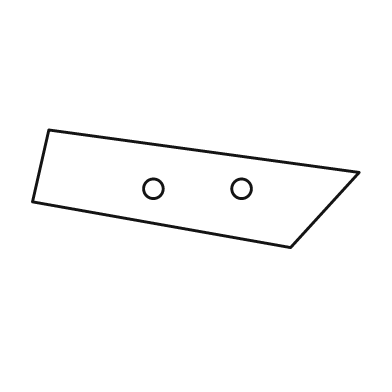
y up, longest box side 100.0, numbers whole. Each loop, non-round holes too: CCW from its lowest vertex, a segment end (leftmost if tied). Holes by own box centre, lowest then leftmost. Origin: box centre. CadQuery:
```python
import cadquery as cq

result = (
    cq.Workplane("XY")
    .moveTo(29.0, -18.0)
    .lineTo(50.0, 5.0)
    .lineTo(-45.0, 18.0)
    .lineTo(-50.0, -4.0)
    .close()
    .moveTo(-13.0, 0.0)
    .circle(3.0)
    .moveTo(14.0, 0.0)
    .circle(3.0)
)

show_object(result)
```